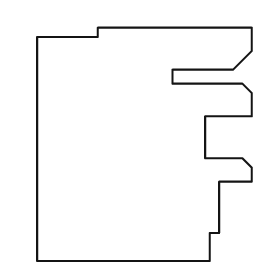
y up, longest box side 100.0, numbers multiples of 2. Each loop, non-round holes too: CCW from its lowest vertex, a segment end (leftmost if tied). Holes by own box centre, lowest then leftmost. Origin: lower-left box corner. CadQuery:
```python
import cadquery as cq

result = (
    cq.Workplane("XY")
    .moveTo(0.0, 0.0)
    .lineTo(74.0, 0.0)
    .lineTo(74.0, 12.0)
    .lineTo(78.0, 12.0)
    .lineTo(78.0, 34.0)
    .lineTo(92.0, 34.0)
    .lineTo(92.0, 40.0)
    .lineTo(88.0, 44.0)
    .lineTo(72.0, 44.0)
    .lineTo(72.0, 62.0)
    .lineTo(92.0, 62.0)
    .lineTo(92.0, 72.0)
    .lineTo(88.0, 76.0)
    .lineTo(58.0, 76.0)
    .lineTo(58.0, 82.0)
    .lineTo(84.0, 82.0)
    .lineTo(92.0, 90.0)
    .lineTo(92.0, 100.0)
    .lineTo(26.0, 100.0)
    .lineTo(26.0, 96.0)
    .lineTo(0.0, 96.0)
    .close()
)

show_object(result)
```